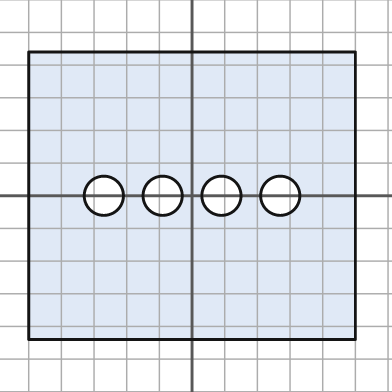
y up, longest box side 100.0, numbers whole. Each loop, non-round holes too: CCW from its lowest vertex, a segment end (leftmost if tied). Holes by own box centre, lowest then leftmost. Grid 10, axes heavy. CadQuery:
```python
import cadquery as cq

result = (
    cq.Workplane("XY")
    .moveTo(-50.0, -44.0)
    .lineTo(50.0, -44.0)
    .lineTo(50.0, 44.0)
    .lineTo(-50.0, 44.0)
    .close()
    .moveTo(-27.0, 0.0)
    .circle(6.0)
    .moveTo(-9.0, 0.0)
    .circle(6.0)
    .moveTo(9.0, 0.0)
    .circle(6.0)
    .moveTo(27.0, 0.0)
    .circle(6.0)
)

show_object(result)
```